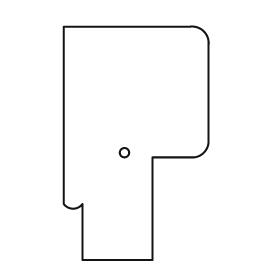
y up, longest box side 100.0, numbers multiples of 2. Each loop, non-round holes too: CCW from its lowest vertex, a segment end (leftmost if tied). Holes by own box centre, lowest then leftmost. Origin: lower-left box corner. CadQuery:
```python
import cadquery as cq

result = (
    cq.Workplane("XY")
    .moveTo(8.0, 0.0)
    .lineTo(38.0, 0.0)
    .lineTo(38.0, 44.0)
    .lineTo(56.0, 44.0)
    .threePointArc((60.0, 46.0), (62.0, 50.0))
    .lineTo(62.0, 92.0)
    .threePointArc((60.0, 98.0), (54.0, 100.0))
    .lineTo(0.0, 100.0)
    .lineTo(0.0, 24.0)
    .threePointArc((4.0, 22.0), (8.0, 24.0))
    .close()
    .moveTo(26.0, 46.0)
    .circle(2.0)
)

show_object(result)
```